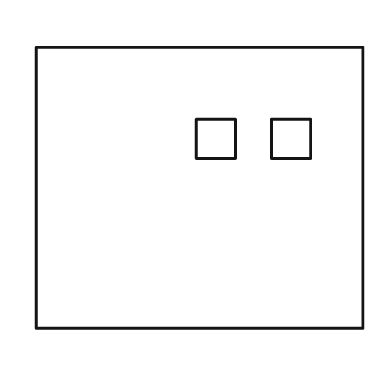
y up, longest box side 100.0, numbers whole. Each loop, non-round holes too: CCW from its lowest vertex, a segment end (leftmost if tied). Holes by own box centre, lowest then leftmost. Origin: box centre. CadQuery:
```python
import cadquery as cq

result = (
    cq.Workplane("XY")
    .moveTo(-50.0, -43.0)
    .lineTo(50.0, -43.0)
    .lineTo(50.0, 43.0)
    .lineTo(-50.0, 43.0)
    .close()
    .moveTo(-1.0, 9.0)
    .lineTo(11.0, 9.0)
    .lineTo(11.0, 21.0)
    .lineTo(-1.0, 21.0)
    .close()
    .moveTo(22.0, 9.0)
    .lineTo(34.0, 9.0)
    .lineTo(34.0, 21.0)
    .lineTo(22.0, 21.0)
    .close()
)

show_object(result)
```